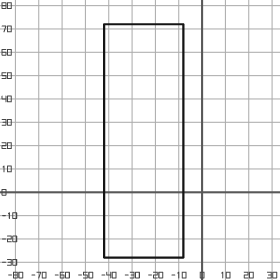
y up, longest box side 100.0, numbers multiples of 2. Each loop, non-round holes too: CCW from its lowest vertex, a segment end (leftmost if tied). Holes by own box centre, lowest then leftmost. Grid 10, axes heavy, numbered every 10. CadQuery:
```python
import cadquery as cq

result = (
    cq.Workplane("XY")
    .moveTo(-42.0, -28.0)
    .lineTo(-8.0, -28.0)
    .lineTo(-8.0, 72.0)
    .lineTo(-42.0, 72.0)
    .close()
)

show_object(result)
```